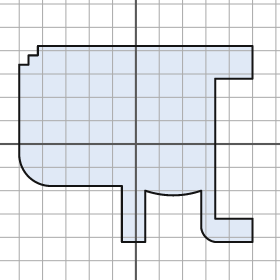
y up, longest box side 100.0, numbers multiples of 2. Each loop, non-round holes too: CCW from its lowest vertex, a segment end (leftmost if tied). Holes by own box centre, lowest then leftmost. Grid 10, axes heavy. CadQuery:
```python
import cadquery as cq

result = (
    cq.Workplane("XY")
    .moveTo(-6.0, -42.0)
    .lineTo(4.0, -42.0)
    .lineTo(4.0, -20.0)
    .threePointArc((16.0, -22.0), (28.0, -20.0))
    .lineTo(28.0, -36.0)
    .threePointArc((30.0, -40.0), (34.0, -42.0))
    .lineTo(50.0, -42.0)
    .lineTo(50.0, -32.0)
    .lineTo(34.0, -32.0)
    .lineTo(34.0, 28.0)
    .lineTo(50.0, 28.0)
    .lineTo(50.0, 42.0)
    .lineTo(-42.0, 42.0)
    .lineTo(-42.0, 38.0)
    .lineTo(-46.0, 38.0)
    .lineTo(-46.0, 34.0)
    .lineTo(-50.0, 34.0)
    .lineTo(-50.0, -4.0)
    .threePointArc((-46.0, -14.0), (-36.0, -18.0))
    .lineTo(-6.0, -18.0)
    .close()
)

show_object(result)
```